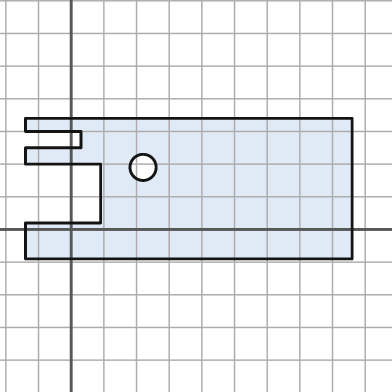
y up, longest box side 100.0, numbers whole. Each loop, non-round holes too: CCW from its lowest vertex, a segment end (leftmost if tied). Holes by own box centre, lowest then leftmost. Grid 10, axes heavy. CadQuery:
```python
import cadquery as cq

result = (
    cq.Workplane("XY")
    .moveTo(-14.0, -9.0)
    .lineTo(86.0, -9.0)
    .lineTo(86.0, 34.0)
    .lineTo(-14.0, 34.0)
    .lineTo(-14.0, 30.0)
    .lineTo(3.0, 30.0)
    .lineTo(3.0, 25.0)
    .lineTo(-14.0, 25.0)
    .lineTo(-14.0, 20.0)
    .lineTo(9.0, 20.0)
    .lineTo(9.0, 2.0)
    .lineTo(-14.0, 2.0)
    .close()
    .moveTo(22.0, 19.0)
    .circle(4.0)
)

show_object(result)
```